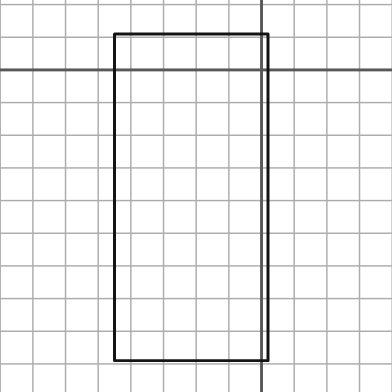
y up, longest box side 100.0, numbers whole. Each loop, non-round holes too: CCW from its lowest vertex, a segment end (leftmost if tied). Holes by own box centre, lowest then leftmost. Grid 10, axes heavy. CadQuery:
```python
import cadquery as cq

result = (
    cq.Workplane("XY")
    .moveTo(-45.0, -89.0)
    .lineTo(2.0, -89.0)
    .lineTo(2.0, 11.0)
    .lineTo(-45.0, 11.0)
    .close()
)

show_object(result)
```